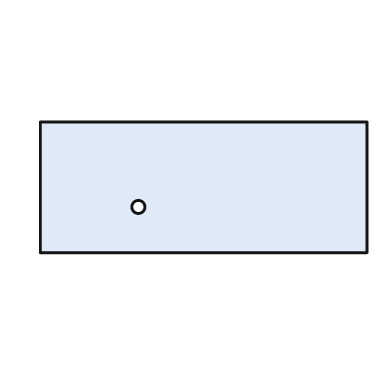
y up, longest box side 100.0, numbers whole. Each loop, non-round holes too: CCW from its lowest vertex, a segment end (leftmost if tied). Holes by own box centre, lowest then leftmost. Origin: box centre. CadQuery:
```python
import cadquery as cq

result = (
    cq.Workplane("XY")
    .moveTo(-50.0, -20.0)
    .lineTo(50.0, -20.0)
    .lineTo(50.0, 20.0)
    .lineTo(-50.0, 20.0)
    .close()
    .moveTo(-20.0, -6.0)
    .circle(2.0)
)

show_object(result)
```